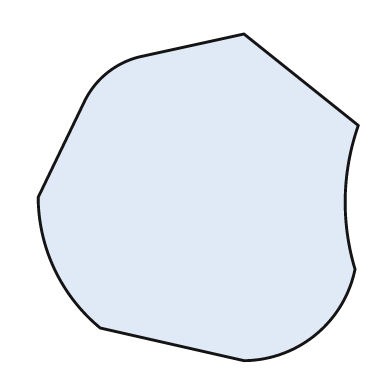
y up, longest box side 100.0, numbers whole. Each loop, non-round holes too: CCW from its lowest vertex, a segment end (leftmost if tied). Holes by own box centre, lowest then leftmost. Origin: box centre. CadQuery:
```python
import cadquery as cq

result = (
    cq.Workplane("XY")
    .moveTo(14.0, -50.0)
    .threePointArc((36.0, -42.0), (48.0, -22.0))
    .threePointArc((45.0, 0.0), (49.0, 22.0))
    .lineTo(14.0, 50.0)
    .lineTo(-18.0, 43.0)
    .threePointArc((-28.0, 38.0), (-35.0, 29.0))
    .lineTo(-49.0, 0.0)
    .threePointArc((-44.0, -22.0), (-30.0, -40.0))
    .close()
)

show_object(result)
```